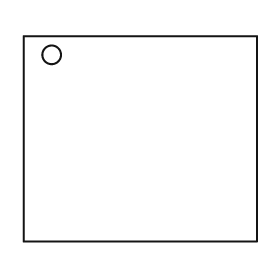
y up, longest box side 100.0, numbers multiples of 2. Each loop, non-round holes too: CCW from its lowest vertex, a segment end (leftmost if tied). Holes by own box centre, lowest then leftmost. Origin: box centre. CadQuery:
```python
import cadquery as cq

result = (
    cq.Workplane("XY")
    .moveTo(-50.0, -44.0)
    .lineTo(50.0, -44.0)
    .lineTo(50.0, 44.0)
    .lineTo(-50.0, 44.0)
    .close()
    .moveTo(-38.0, 36.0)
    .circle(4.0)
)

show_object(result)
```